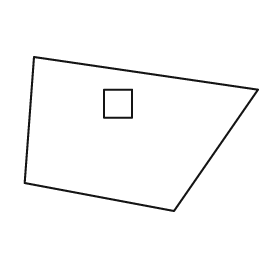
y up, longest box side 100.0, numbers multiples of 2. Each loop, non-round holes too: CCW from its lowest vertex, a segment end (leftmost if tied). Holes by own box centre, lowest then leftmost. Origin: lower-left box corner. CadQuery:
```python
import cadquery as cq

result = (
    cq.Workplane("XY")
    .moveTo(64.0, 0.0)
    .lineTo(100.0, 52.0)
    .lineTo(4.0, 66.0)
    .lineTo(0.0, 12.0)
    .close()
    .moveTo(34.0, 40.0)
    .lineTo(46.0, 40.0)
    .lineTo(46.0, 52.0)
    .lineTo(34.0, 52.0)
    .close()
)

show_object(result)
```